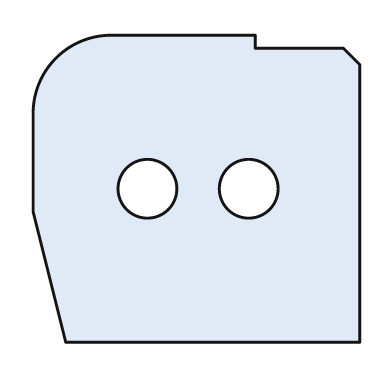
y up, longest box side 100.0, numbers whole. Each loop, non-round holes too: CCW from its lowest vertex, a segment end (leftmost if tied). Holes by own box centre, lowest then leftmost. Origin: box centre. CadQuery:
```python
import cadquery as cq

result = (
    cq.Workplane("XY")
    .moveTo(-40.0, -47.0)
    .lineTo(50.0, -47.0)
    .lineTo(50.0, 38.0)
    .lineTo(45.0, 43.0)
    .lineTo(18.0, 43.0)
    .lineTo(18.0, 47.0)
    .lineTo(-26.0, 47.0)
    .threePointArc((-43.0, 40.0), (-50.0, 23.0))
    .lineTo(-50.0, -7.0)
    .close()
    .moveTo(-15.0, 0.0)
    .circle(9.0)
    .moveTo(16.0, 0.0)
    .circle(9.0)
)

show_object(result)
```